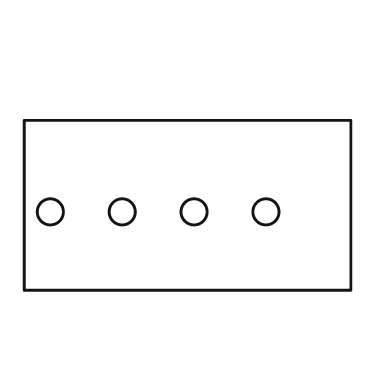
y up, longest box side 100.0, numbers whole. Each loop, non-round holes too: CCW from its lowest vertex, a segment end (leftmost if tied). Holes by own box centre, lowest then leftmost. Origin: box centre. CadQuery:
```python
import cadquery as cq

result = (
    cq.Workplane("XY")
    .moveTo(-50.0, -26.0)
    .lineTo(50.0, -26.0)
    .lineTo(50.0, 26.0)
    .lineTo(-50.0, 26.0)
    .close()
    .moveTo(-42.0, -2.0)
    .circle(4.0)
    .moveTo(-20.0, -2.0)
    .circle(4.0)
    .moveTo(2.0, -2.0)
    .circle(4.0)
    .moveTo(24.0, -2.0)
    .circle(4.0)
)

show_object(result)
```